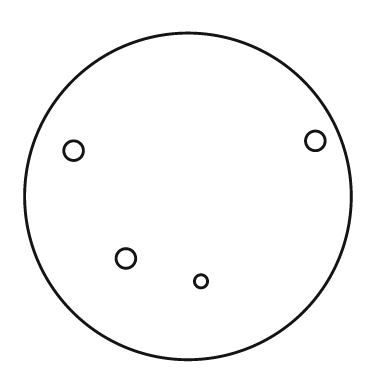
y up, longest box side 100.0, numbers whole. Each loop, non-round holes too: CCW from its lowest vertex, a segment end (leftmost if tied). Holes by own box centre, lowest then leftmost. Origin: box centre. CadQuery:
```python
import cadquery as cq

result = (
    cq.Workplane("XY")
    .moveTo(0.0, 0.0)
    .circle(50.0)
    .moveTo(4.0, -26.0)
    .circle(2.0)
    .moveTo(-19.0, -19.0)
    .circle(3.0)
    .moveTo(-35.0, 14.0)
    .circle(3.0)
    .moveTo(39.0, 17.0)
    .circle(3.0)
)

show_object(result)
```